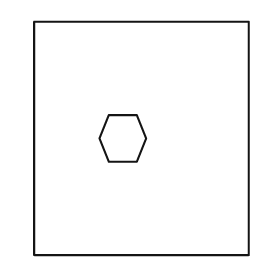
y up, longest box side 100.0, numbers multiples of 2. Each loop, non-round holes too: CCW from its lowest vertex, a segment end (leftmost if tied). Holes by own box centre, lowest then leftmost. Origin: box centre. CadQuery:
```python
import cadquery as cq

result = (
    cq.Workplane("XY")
    .moveTo(-46.0, -50.0)
    .lineTo(46.0, -50.0)
    .lineTo(46.0, 50.0)
    .lineTo(-46.0, 50.0)
    .close()
    .moveTo(-14.0, -10.0)
    .lineTo(-2.0, -10.0)
    .lineTo(2.0, 0.0)
    .lineTo(-2.0, 10.0)
    .lineTo(-14.0, 10.0)
    .lineTo(-18.0, 0.0)
    .close()
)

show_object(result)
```